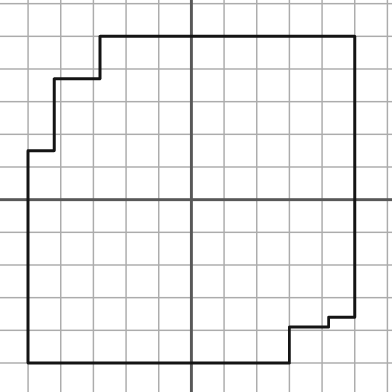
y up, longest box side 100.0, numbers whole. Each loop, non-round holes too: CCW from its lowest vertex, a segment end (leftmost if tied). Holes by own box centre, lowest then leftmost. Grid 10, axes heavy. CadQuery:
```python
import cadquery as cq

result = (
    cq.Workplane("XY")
    .moveTo(-50.0, -50.0)
    .lineTo(30.0, -50.0)
    .lineTo(30.0, -39.0)
    .lineTo(42.0, -39.0)
    .lineTo(42.0, -36.0)
    .lineTo(50.0, -36.0)
    .lineTo(50.0, 50.0)
    .lineTo(-28.0, 50.0)
    .lineTo(-28.0, 37.0)
    .lineTo(-42.0, 37.0)
    .lineTo(-42.0, 15.0)
    .lineTo(-50.0, 15.0)
    .close()
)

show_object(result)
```